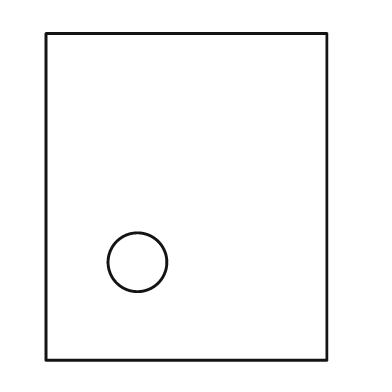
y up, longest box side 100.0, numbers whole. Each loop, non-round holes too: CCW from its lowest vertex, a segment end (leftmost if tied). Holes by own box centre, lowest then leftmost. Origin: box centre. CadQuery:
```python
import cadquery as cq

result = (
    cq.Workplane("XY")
    .moveTo(-43.0, -50.0)
    .lineTo(43.0, -50.0)
    .lineTo(43.0, 50.0)
    .lineTo(-43.0, 50.0)
    .close()
    .moveTo(-15.0, -20.0)
    .circle(9.0)
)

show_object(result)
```